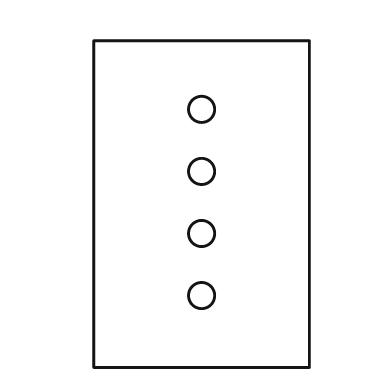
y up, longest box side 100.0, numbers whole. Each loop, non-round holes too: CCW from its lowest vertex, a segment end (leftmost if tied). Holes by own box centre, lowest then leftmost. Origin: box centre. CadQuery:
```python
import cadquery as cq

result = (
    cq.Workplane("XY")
    .moveTo(-33.0, -50.0)
    .lineTo(33.0, -50.0)
    .lineTo(33.0, 50.0)
    .lineTo(-33.0, 50.0)
    .close()
    .moveTo(0.0, -28.0)
    .circle(4.0)
    .moveTo(0.0, -9.0)
    .circle(4.0)
    .moveTo(0.0, 10.0)
    .circle(4.0)
    .moveTo(0.0, 29.0)
    .circle(4.0)
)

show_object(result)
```